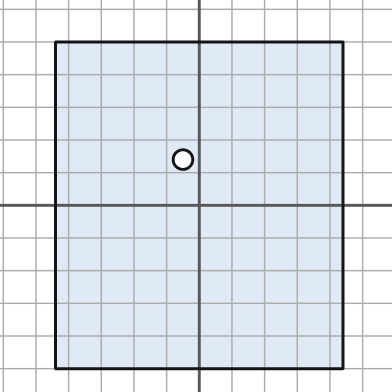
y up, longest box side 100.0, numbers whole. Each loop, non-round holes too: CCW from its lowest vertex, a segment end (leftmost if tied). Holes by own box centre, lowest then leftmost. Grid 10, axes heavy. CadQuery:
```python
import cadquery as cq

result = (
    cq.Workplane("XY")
    .moveTo(-44.0, -50.0)
    .lineTo(44.0, -50.0)
    .lineTo(44.0, 50.0)
    .lineTo(-44.0, 50.0)
    .close()
    .moveTo(-5.0, 14.0)
    .circle(3.0)
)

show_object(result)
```